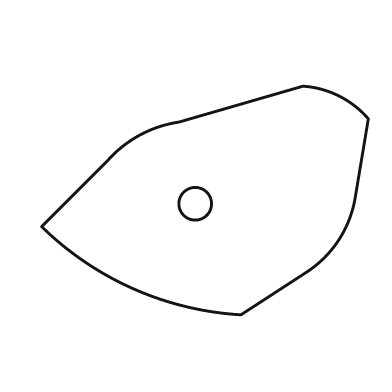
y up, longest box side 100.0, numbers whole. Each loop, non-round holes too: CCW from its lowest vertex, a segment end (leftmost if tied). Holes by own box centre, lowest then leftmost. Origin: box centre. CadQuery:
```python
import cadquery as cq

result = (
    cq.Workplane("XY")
    .moveTo(11.0, -35.0)
    .lineTo(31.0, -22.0)
    .threePointArc((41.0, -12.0), (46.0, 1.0))
    .lineTo(50.0, 25.0)
    .threePointArc((41.0, 32.0), (30.0, 35.0))
    .lineTo(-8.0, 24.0)
    .threePointArc((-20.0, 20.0), (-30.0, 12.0))
    .lineTo(-50.0, -8.0)
    .threePointArc((-22.0, -27.0), (11.0, -35.0))
    .close()
    .moveTo(-3.0, -1.0)
    .circle(5.0)
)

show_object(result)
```